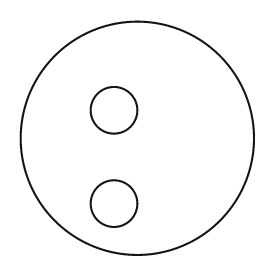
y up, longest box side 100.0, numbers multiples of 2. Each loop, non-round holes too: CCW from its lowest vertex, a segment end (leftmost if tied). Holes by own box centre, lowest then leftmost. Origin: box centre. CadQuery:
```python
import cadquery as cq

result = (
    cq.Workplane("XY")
    .moveTo(0.0, 0.0)
    .circle(50.0)
    .moveTo(-10.0, -28.0)
    .circle(10.0)
    .moveTo(-10.0, 12.0)
    .circle(10.0)
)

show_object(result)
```